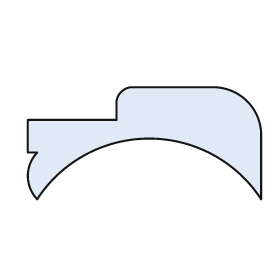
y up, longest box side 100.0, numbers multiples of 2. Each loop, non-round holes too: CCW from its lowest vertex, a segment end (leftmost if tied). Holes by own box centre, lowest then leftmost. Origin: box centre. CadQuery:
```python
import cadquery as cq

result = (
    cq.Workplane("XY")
    .moveTo(-46.0, -24.0)
    .threePointArc((2.0, 2.0), (50.0, -24.0))
    .lineTo(50.0, 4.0)
    .threePointArc((44.0, 18.0), (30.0, 24.0))
    .lineTo(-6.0, 24.0)
    .threePointArc((-10.0, 22.0), (-12.0, 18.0))
    .lineTo(-12.0, 10.0)
    .lineTo(-50.0, 10.0)
    .lineTo(-50.0, -4.0)
    .lineTo(-46.0, -4.0)
    .threePointArc((-50.0, -14.0), (-46.0, -24.0))
    .close()
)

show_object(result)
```